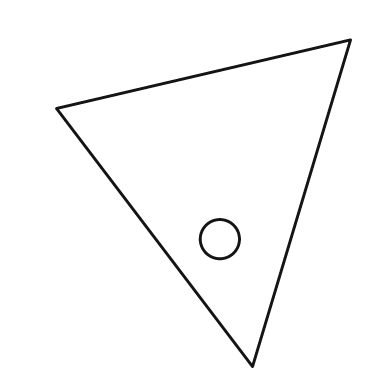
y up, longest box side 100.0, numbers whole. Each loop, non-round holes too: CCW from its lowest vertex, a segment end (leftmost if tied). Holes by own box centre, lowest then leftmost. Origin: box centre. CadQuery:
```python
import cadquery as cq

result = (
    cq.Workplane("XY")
    .moveTo(15.0, -50.0)
    .lineTo(45.0, 50.0)
    .lineTo(-45.0, 29.0)
    .close()
    .moveTo(5.0, -11.0)
    .circle(6.0)
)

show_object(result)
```